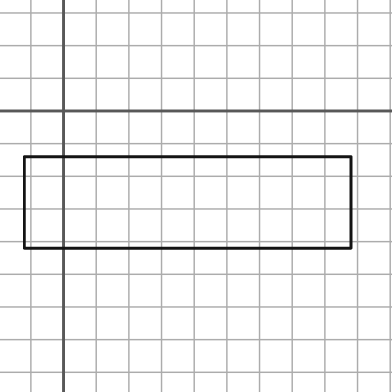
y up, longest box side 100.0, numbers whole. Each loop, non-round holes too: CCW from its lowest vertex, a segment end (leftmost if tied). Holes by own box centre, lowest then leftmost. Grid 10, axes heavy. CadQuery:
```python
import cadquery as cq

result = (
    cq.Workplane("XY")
    .moveTo(-12.0, -42.0)
    .lineTo(88.0, -42.0)
    .lineTo(88.0, -14.0)
    .lineTo(-12.0, -14.0)
    .close()
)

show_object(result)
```